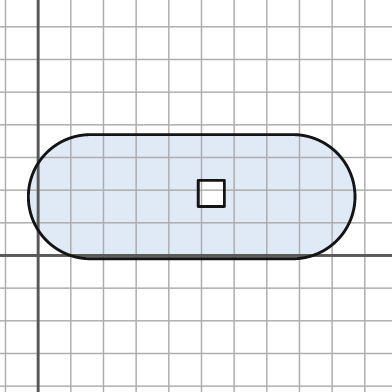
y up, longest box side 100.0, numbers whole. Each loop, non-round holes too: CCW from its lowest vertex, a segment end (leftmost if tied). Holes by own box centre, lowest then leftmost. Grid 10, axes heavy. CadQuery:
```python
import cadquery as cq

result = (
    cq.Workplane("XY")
    .moveTo(16.0, -1.0)
    .lineTo(78.0, -1.0)
    .threePointArc((97.0, 18.0), (78.0, 37.0))
    .lineTo(16.0, 37.0)
    .threePointArc((-3.0, 18.0), (16.0, -1.0))
    .close()
    .moveTo(49.0, 15.0)
    .lineTo(57.0, 15.0)
    .lineTo(57.0, 23.0)
    .lineTo(49.0, 23.0)
    .close()
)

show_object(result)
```